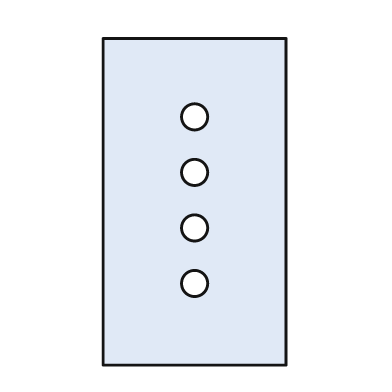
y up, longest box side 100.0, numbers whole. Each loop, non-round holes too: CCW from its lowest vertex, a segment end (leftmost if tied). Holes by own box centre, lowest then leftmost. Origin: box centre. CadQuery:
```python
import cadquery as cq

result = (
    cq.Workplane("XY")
    .moveTo(-28.0, -50.0)
    .lineTo(28.0, -50.0)
    .lineTo(28.0, 50.0)
    .lineTo(-28.0, 50.0)
    .close()
    .moveTo(0.0, -25.0)
    .circle(4.0)
    .moveTo(0.0, -8.0)
    .circle(4.0)
    .moveTo(0.0, 9.0)
    .circle(4.0)
    .moveTo(0.0, 26.0)
    .circle(4.0)
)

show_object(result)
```